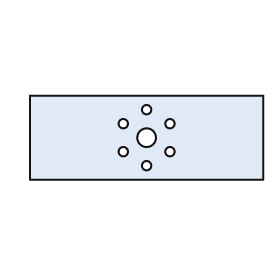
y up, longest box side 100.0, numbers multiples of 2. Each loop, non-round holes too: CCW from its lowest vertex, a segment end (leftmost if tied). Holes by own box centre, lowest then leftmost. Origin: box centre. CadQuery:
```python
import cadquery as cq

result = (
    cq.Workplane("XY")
    .moveTo(-50.0, -18.0)
    .lineTo(50.0, -18.0)
    .lineTo(50.0, 18.0)
    .lineTo(-50.0, 18.0)
    .close()
    .moveTo(0.0, -12.0)
    .circle(2.0)
    .moveTo(-10.0, -6.0)
    .circle(2.0)
    .moveTo(10.0, -6.0)
    .circle(2.0)
    .moveTo(0.0, 0.0)
    .circle(4.0)
    .moveTo(-10.0, 6.0)
    .circle(2.0)
    .moveTo(10.0, 6.0)
    .circle(2.0)
    .moveTo(0.0, 12.0)
    .circle(2.0)
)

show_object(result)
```